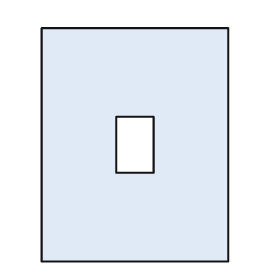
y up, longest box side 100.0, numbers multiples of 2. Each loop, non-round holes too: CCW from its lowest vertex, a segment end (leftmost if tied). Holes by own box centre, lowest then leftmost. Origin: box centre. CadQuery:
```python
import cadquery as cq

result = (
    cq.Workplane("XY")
    .moveTo(-40.0, -50.0)
    .lineTo(40.0, -50.0)
    .lineTo(40.0, 50.0)
    .lineTo(-40.0, 50.0)
    .close()
    .moveTo(-8.0, -12.0)
    .lineTo(8.0, -12.0)
    .lineTo(8.0, 12.0)
    .lineTo(-8.0, 12.0)
    .close()
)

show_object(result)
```